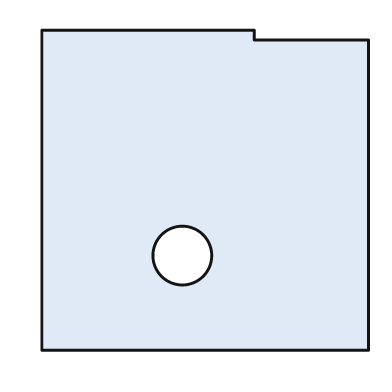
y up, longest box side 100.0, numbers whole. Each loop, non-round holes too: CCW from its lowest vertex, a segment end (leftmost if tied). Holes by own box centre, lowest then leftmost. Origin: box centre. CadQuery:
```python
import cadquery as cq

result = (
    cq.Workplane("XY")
    .moveTo(-50.0, -49.0)
    .lineTo(50.0, -49.0)
    .lineTo(50.0, 46.0)
    .lineTo(15.0, 46.0)
    .lineTo(15.0, 49.0)
    .lineTo(-50.0, 49.0)
    .close()
    .moveTo(-7.0, -20.0)
    .circle(9.0)
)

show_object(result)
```